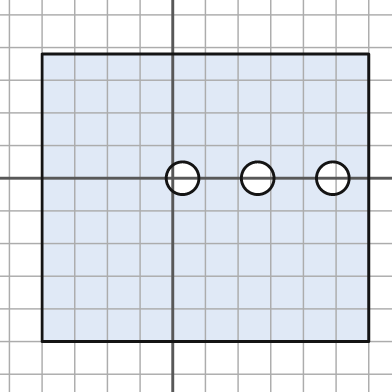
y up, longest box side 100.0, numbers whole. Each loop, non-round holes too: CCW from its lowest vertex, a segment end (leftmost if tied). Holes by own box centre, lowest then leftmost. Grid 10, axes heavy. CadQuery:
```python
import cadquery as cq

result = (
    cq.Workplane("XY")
    .moveTo(-40.0, -50.0)
    .lineTo(60.0, -50.0)
    .lineTo(60.0, 38.0)
    .lineTo(-40.0, 38.0)
    .close()
    .moveTo(3.0, 0.0)
    .circle(5.0)
    .moveTo(26.0, 0.0)
    .circle(5.0)
    .moveTo(49.0, 0.0)
    .circle(5.0)
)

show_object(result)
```